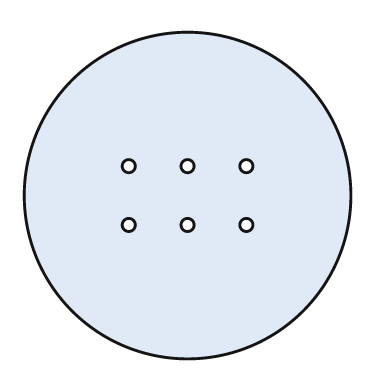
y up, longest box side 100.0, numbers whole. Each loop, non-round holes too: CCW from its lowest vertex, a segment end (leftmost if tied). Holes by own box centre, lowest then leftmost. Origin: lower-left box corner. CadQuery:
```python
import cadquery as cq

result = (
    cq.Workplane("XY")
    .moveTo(50.0, 50.0)
    .circle(50.0)
    .moveTo(32.0, 41.0)
    .circle(2.0)
    .moveTo(50.0, 41.0)
    .circle(2.0)
    .moveTo(68.0, 41.0)
    .circle(2.0)
    .moveTo(32.0, 59.0)
    .circle(2.0)
    .moveTo(50.0, 59.0)
    .circle(2.0)
    .moveTo(68.0, 59.0)
    .circle(2.0)
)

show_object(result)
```